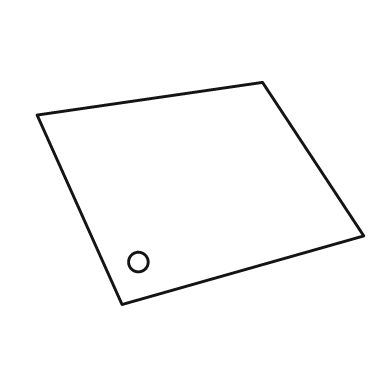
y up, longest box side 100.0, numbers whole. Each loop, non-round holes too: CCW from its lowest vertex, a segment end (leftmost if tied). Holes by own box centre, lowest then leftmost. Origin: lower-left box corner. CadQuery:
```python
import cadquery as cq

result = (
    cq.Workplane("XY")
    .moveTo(26.0, 0.0)
    .lineTo(100.0, 21.0)
    .lineTo(69.0, 68.0)
    .lineTo(0.0, 58.0)
    .close()
    .moveTo(31.0, 13.0)
    .circle(3.0)
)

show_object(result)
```